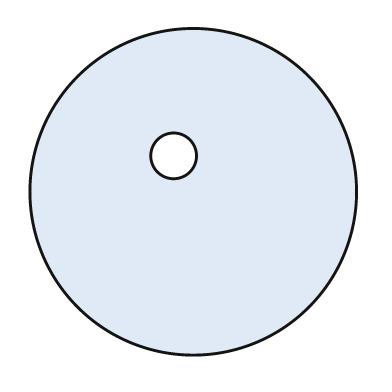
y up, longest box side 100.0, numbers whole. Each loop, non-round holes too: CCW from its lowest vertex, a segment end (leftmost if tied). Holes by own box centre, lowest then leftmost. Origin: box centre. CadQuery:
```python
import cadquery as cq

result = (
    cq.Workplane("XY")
    .moveTo(0.0, 0.0)
    .circle(50.0)
    .moveTo(-6.0, 11.0)
    .circle(7.0)
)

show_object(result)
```